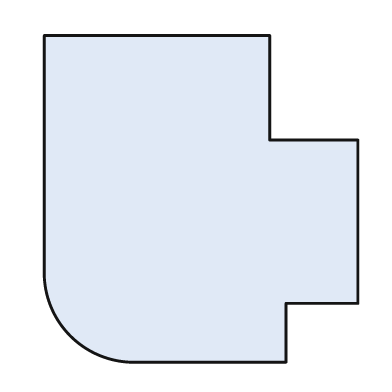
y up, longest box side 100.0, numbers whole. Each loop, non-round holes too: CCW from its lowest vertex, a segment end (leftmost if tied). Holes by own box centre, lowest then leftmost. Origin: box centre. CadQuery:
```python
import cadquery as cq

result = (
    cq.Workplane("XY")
    .moveTo(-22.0, -50.0)
    .lineTo(26.0, -50.0)
    .lineTo(26.0, -32.0)
    .lineTo(48.0, -32.0)
    .lineTo(48.0, 18.0)
    .lineTo(21.0, 18.0)
    .lineTo(21.0, 50.0)
    .lineTo(-48.0, 50.0)
    .lineTo(-48.0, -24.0)
    .threePointArc((-40.0, -42.0), (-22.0, -50.0))
    .close()
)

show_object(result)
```